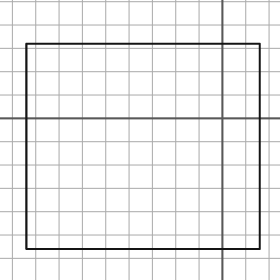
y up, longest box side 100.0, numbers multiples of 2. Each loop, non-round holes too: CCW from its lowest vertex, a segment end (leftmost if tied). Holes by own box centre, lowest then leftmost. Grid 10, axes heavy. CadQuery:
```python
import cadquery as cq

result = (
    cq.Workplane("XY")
    .moveTo(-84.0, -56.0)
    .lineTo(16.0, -56.0)
    .lineTo(16.0, 32.0)
    .lineTo(-84.0, 32.0)
    .close()
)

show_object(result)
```